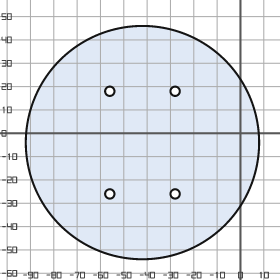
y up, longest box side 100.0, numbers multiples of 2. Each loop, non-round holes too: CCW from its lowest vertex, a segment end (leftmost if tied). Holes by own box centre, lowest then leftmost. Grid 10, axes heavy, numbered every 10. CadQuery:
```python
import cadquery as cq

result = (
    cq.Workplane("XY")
    .moveTo(-42.0, -4.0)
    .circle(50.0)
    .moveTo(-56.0, -26.0)
    .circle(2.0)
    .moveTo(-28.0, -26.0)
    .circle(2.0)
    .moveTo(-56.0, 18.0)
    .circle(2.0)
    .moveTo(-28.0, 18.0)
    .circle(2.0)
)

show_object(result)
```